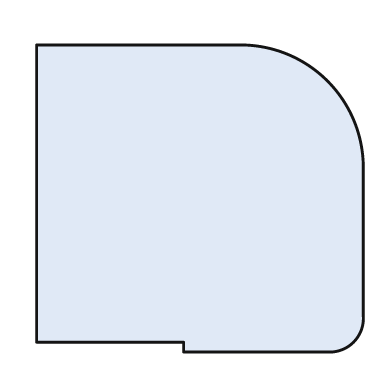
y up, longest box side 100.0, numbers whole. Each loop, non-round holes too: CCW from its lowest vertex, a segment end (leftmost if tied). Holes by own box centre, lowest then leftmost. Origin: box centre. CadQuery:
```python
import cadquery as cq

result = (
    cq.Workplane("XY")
    .moveTo(-5.0, -47.0)
    .lineTo(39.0, -47.0)
    .threePointArc((47.0, -44.0), (50.0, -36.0))
    .lineTo(50.0, 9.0)
    .threePointArc((39.0, 36.0), (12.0, 47.0))
    .lineTo(-50.0, 47.0)
    .lineTo(-50.0, -44.0)
    .lineTo(-5.0, -44.0)
    .close()
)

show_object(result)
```